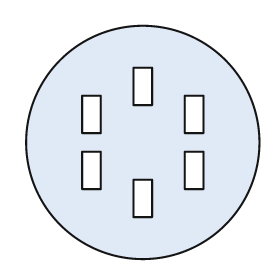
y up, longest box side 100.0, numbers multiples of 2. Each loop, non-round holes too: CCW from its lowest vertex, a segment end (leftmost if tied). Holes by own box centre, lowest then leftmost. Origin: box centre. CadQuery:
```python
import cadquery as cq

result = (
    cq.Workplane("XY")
    .moveTo(0.0, 0.0)
    .circle(50.0)
    .moveTo(-4.0, -32.0)
    .lineTo(4.0, -32.0)
    .lineTo(4.0, -16.0)
    .lineTo(-4.0, -16.0)
    .close()
    .moveTo(-26.0, -20.0)
    .lineTo(-18.0, -20.0)
    .lineTo(-18.0, -4.0)
    .lineTo(-26.0, -4.0)
    .close()
    .moveTo(18.0, -20.0)
    .lineTo(26.0, -20.0)
    .lineTo(26.0, -4.0)
    .lineTo(18.0, -4.0)
    .close()
    .moveTo(-26.0, 4.0)
    .lineTo(-18.0, 4.0)
    .lineTo(-18.0, 20.0)
    .lineTo(-26.0, 20.0)
    .close()
    .moveTo(18.0, 4.0)
    .lineTo(26.0, 4.0)
    .lineTo(26.0, 20.0)
    .lineTo(18.0, 20.0)
    .close()
    .moveTo(-4.0, 16.0)
    .lineTo(4.0, 16.0)
    .lineTo(4.0, 32.0)
    .lineTo(-4.0, 32.0)
    .close()
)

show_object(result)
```